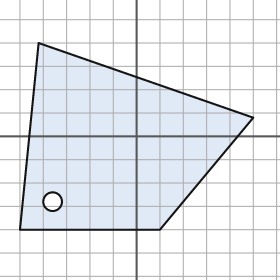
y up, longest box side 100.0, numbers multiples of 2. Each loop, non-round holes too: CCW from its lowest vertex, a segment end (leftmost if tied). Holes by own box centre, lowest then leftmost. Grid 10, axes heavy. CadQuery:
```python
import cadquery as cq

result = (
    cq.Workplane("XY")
    .moveTo(-50.0, -40.0)
    .lineTo(10.0, -40.0)
    .lineTo(50.0, 8.0)
    .lineTo(-42.0, 40.0)
    .close()
    .moveTo(-36.0, -28.0)
    .circle(4.0)
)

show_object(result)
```